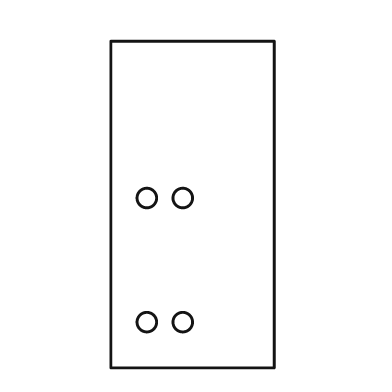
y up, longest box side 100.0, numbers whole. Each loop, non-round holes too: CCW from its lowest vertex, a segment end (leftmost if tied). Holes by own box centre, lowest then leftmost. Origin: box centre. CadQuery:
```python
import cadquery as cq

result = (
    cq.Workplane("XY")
    .moveTo(-25.0, -50.0)
    .lineTo(25.0, -50.0)
    .lineTo(25.0, 50.0)
    .lineTo(-25.0, 50.0)
    .close()
    .moveTo(-14.0, -36.0)
    .circle(3.0)
    .moveTo(-3.0, -36.0)
    .circle(3.0)
    .moveTo(-14.0, 2.0)
    .circle(3.0)
    .moveTo(-3.0, 2.0)
    .circle(3.0)
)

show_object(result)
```